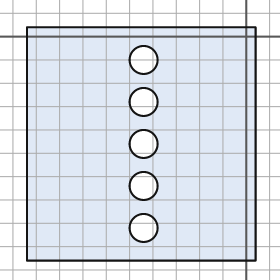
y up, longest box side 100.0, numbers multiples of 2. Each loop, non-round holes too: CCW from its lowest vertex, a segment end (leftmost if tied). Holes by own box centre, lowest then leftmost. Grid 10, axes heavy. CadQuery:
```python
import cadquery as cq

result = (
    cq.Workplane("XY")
    .moveTo(-94.0, -96.0)
    .lineTo(4.0, -96.0)
    .lineTo(4.0, 4.0)
    .lineTo(-94.0, 4.0)
    .close()
    .moveTo(-44.0, -82.0)
    .circle(6.0)
    .moveTo(-44.0, -64.0)
    .circle(6.0)
    .moveTo(-44.0, -46.0)
    .circle(6.0)
    .moveTo(-44.0, -28.0)
    .circle(6.0)
    .moveTo(-44.0, -10.0)
    .circle(6.0)
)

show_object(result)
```